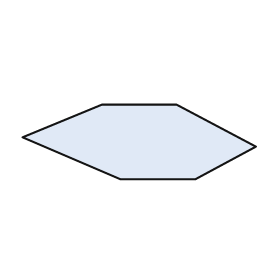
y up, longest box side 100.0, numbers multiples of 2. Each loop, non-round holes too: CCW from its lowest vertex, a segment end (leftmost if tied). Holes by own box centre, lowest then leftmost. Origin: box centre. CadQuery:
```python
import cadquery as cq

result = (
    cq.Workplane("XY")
    .moveTo(-8.0, -16.0)
    .lineTo(24.0, -16.0)
    .lineTo(50.0, -2.0)
    .lineTo(16.0, 16.0)
    .lineTo(-16.0, 16.0)
    .lineTo(-50.0, 2.0)
    .close()
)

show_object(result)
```